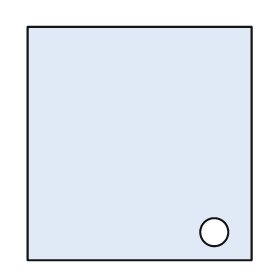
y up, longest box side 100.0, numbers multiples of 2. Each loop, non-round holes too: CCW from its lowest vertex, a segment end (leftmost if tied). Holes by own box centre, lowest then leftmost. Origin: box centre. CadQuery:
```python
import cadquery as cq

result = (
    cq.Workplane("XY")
    .moveTo(-48.0, -50.0)
    .lineTo(48.0, -50.0)
    .lineTo(48.0, 50.0)
    .lineTo(-48.0, 50.0)
    .close()
    .moveTo(32.0, -38.0)
    .circle(6.0)
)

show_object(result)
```